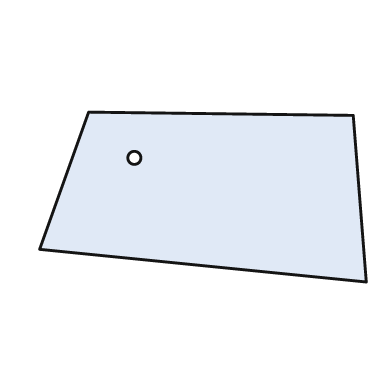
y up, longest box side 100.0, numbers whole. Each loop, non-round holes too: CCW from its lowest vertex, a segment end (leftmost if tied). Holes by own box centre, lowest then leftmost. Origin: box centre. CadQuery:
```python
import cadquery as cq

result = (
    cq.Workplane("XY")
    .moveTo(50.0, -26.0)
    .lineTo(46.0, 25.0)
    .lineTo(-35.0, 26.0)
    .lineTo(-50.0, -16.0)
    .close()
    .moveTo(-21.0, 12.0)
    .circle(2.0)
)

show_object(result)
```